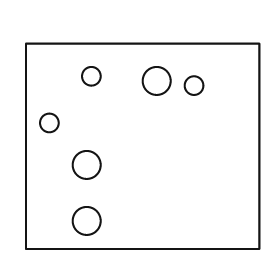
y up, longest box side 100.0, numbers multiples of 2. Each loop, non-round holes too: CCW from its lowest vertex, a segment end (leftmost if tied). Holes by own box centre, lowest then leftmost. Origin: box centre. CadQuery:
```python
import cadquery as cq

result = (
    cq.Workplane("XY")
    .moveTo(-50.0, -44.0)
    .lineTo(50.0, -44.0)
    .lineTo(50.0, 44.0)
    .lineTo(-50.0, 44.0)
    .close()
    .moveTo(-24.0, -32.0)
    .circle(6.0)
    .moveTo(-24.0, -8.0)
    .circle(6.0)
    .moveTo(-40.0, 10.0)
    .circle(4.0)
    .moveTo(22.0, 26.0)
    .circle(4.0)
    .moveTo(6.0, 28.0)
    .circle(6.0)
    .moveTo(-22.0, 30.0)
    .circle(4.0)
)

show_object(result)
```